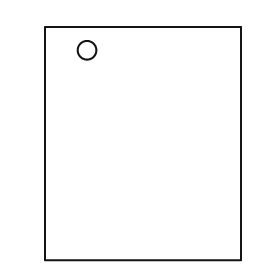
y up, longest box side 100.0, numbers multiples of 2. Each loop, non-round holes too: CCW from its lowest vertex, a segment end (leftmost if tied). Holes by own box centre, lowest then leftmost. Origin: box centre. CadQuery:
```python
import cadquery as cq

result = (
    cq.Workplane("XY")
    .moveTo(-42.0, -50.0)
    .lineTo(42.0, -50.0)
    .lineTo(42.0, 50.0)
    .lineTo(-42.0, 50.0)
    .close()
    .moveTo(-24.0, 40.0)
    .circle(4.0)
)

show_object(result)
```